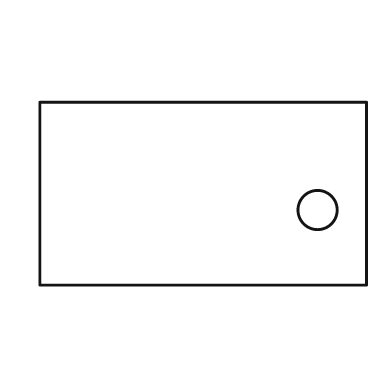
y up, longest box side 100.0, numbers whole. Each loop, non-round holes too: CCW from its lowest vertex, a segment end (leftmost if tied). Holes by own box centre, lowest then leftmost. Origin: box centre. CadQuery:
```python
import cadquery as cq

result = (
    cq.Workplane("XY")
    .moveTo(-50.0, -28.0)
    .lineTo(50.0, -28.0)
    .lineTo(50.0, 28.0)
    .lineTo(-50.0, 28.0)
    .close()
    .moveTo(35.0, -5.0)
    .circle(6.0)
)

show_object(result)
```